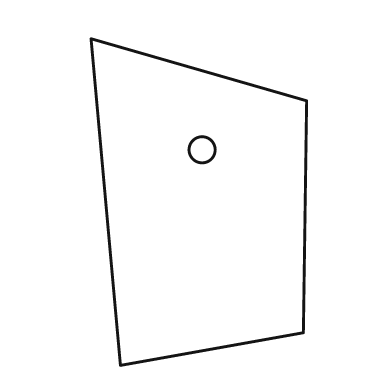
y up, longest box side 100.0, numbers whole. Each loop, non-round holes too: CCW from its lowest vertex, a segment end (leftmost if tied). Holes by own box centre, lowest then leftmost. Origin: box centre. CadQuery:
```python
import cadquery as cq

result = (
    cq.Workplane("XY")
    .moveTo(-24.0, -50.0)
    .lineTo(32.0, -40.0)
    .lineTo(33.0, 31.0)
    .lineTo(-33.0, 50.0)
    .close()
    .moveTo(1.0, 16.0)
    .circle(4.0)
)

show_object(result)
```